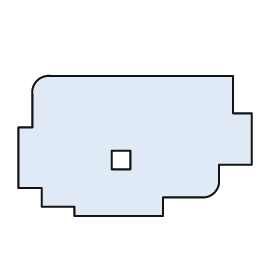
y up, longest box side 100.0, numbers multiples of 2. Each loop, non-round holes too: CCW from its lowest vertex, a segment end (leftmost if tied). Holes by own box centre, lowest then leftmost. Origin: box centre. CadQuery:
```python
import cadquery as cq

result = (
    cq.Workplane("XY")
    .moveTo(-26.0, -30.0)
    .lineTo(12.0, -30.0)
    .lineTo(12.0, -22.0)
    .lineTo(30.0, -22.0)
    .threePointArc((34.0, -20.0), (36.0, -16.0))
    .lineTo(36.0, -8.0)
    .lineTo(50.0, -8.0)
    .lineTo(50.0, 14.0)
    .lineTo(42.0, 14.0)
    .lineTo(42.0, 30.0)
    .lineTo(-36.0, 30.0)
    .threePointArc((-42.0, 28.0), (-44.0, 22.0))
    .lineTo(-44.0, 8.0)
    .lineTo(-50.0, 8.0)
    .lineTo(-50.0, -18.0)
    .lineTo(-40.0, -18.0)
    .lineTo(-40.0, -26.0)
    .lineTo(-26.0, -26.0)
    .close()
    .moveTo(-10.0, -10.0)
    .lineTo(-2.0, -10.0)
    .lineTo(-2.0, -2.0)
    .lineTo(-10.0, -2.0)
    .close()
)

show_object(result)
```